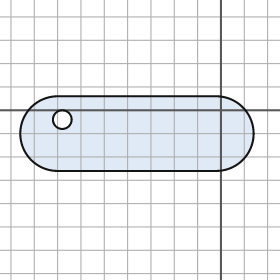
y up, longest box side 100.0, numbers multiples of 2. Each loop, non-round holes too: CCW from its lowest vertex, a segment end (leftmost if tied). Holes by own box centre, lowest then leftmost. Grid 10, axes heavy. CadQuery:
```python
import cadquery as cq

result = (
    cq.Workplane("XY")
    .moveTo(-70.0, -26.0)
    .lineTo(-2.0, -26.0)
    .threePointArc((14.0, -10.0), (-2.0, 6.0))
    .lineTo(-70.0, 6.0)
    .threePointArc((-86.0, -10.0), (-70.0, -26.0))
    .close()
    .moveTo(-68.0, -4.0)
    .circle(4.0)
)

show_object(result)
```